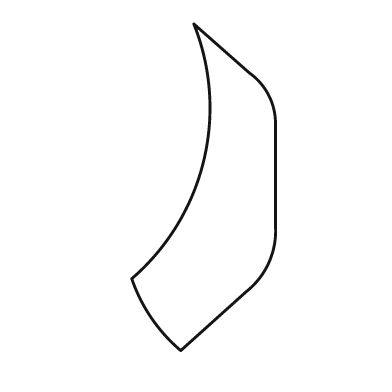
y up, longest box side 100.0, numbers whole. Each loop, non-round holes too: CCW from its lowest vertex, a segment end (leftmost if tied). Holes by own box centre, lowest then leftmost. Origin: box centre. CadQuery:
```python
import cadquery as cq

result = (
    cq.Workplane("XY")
    .moveTo(-7.0, -50.0)
    .lineTo(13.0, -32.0)
    .threePointArc((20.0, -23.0), (22.0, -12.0))
    .lineTo(22.0, 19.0)
    .threePointArc((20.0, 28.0), (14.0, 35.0))
    .lineTo(-3.0, 50.0)
    .threePointArc((0.0, 8.0), (-22.0, -28.0))
    .threePointArc((-16.0, -40.0), (-7.0, -50.0))
    .close()
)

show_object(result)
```